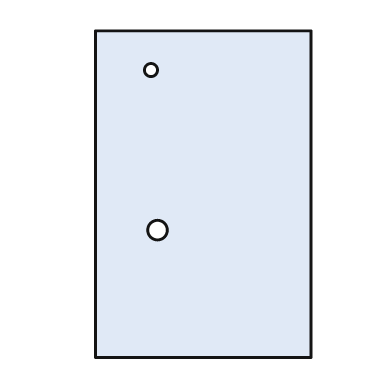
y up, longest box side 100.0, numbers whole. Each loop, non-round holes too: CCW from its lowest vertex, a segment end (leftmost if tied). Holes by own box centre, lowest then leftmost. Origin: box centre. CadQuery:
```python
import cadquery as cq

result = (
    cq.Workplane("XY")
    .moveTo(-33.0, -50.0)
    .lineTo(33.0, -50.0)
    .lineTo(33.0, 50.0)
    .lineTo(-33.0, 50.0)
    .close()
    .moveTo(-14.0, -11.0)
    .circle(3.0)
    .moveTo(-16.0, 38.0)
    .circle(2.0)
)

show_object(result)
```